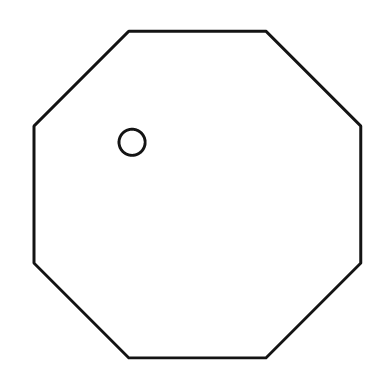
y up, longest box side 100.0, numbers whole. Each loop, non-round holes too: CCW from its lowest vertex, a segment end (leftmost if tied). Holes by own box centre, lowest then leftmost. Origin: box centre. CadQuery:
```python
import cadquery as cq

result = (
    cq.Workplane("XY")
    .moveTo(-21.0, -50.0)
    .lineTo(21.0, -50.0)
    .lineTo(50.0, -21.0)
    .lineTo(50.0, 21.0)
    .lineTo(21.0, 50.0)
    .lineTo(-21.0, 50.0)
    .lineTo(-50.0, 21.0)
    .lineTo(-50.0, -21.0)
    .close()
    .moveTo(-20.0, 16.0)
    .circle(4.0)
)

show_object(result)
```